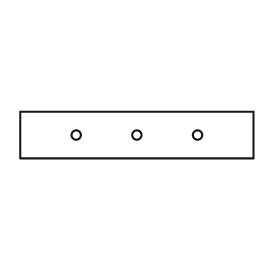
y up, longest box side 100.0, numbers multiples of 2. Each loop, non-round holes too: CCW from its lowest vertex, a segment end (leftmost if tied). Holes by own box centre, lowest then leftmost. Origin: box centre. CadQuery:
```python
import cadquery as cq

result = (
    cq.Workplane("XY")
    .moveTo(-50.0, -10.0)
    .lineTo(50.0, -10.0)
    .lineTo(50.0, 10.0)
    .lineTo(-50.0, 10.0)
    .close()
    .moveTo(-26.0, 0.0)
    .circle(2.0)
    .moveTo(0.0, 0.0)
    .circle(2.0)
    .moveTo(26.0, 0.0)
    .circle(2.0)
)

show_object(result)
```